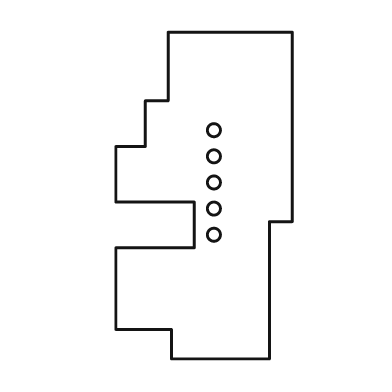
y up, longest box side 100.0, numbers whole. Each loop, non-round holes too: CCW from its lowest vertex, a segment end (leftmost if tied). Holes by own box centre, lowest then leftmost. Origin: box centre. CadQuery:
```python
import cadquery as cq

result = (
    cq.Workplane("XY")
    .moveTo(-10.0, -50.0)
    .lineTo(20.0, -50.0)
    .lineTo(20.0, -8.0)
    .lineTo(27.0, -8.0)
    .lineTo(27.0, 50.0)
    .lineTo(-11.0, 50.0)
    .lineTo(-11.0, 29.0)
    .lineTo(-18.0, 29.0)
    .lineTo(-18.0, 15.0)
    .lineTo(-27.0, 15.0)
    .lineTo(-27.0, -2.0)
    .lineTo(-3.0, -2.0)
    .lineTo(-3.0, -16.0)
    .lineTo(-27.0, -16.0)
    .lineTo(-27.0, -41.0)
    .lineTo(-10.0, -41.0)
    .close()
    .moveTo(3.0, -12.0)
    .circle(2.0)
    .moveTo(3.0, -4.0)
    .circle(2.0)
    .moveTo(3.0, 4.0)
    .circle(2.0)
    .moveTo(3.0, 12.0)
    .circle(2.0)
    .moveTo(3.0, 20.0)
    .circle(2.0)
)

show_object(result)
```